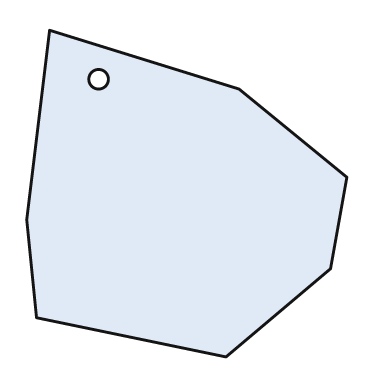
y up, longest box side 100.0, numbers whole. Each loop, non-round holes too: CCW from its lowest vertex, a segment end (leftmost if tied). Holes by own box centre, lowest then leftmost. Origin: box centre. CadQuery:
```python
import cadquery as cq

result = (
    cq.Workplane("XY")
    .moveTo(12.0, -50.0)
    .lineTo(44.0, -23.0)
    .lineTo(49.0, 5.0)
    .lineTo(16.0, 32.0)
    .lineTo(-42.0, 50.0)
    .lineTo(-49.0, -8.0)
    .lineTo(-46.0, -38.0)
    .close()
    .moveTo(-27.0, 35.0)
    .circle(3.0)
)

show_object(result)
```